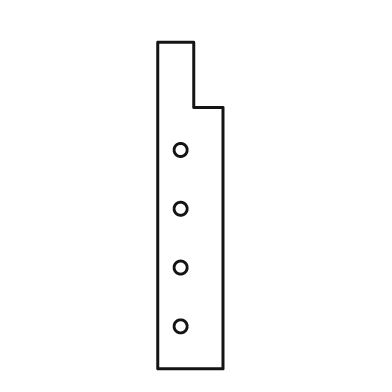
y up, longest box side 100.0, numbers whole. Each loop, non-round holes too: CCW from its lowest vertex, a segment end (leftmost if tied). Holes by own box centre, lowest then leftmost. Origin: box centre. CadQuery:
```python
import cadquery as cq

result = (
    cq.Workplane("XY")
    .moveTo(-10.0, -50.0)
    .lineTo(10.0, -50.0)
    .lineTo(10.0, 30.0)
    .lineTo(1.0, 30.0)
    .lineTo(1.0, 50.0)
    .lineTo(-10.0, 50.0)
    .close()
    .moveTo(-3.0, -37.0)
    .circle(2.0)
    .moveTo(-3.0, -19.0)
    .circle(2.0)
    .moveTo(-3.0, -1.0)
    .circle(2.0)
    .moveTo(-3.0, 17.0)
    .circle(2.0)
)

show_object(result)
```